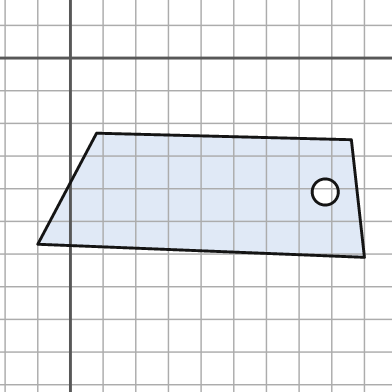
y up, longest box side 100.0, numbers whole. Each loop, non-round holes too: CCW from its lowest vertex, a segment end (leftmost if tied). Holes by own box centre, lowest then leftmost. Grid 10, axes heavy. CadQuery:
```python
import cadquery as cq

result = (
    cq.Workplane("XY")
    .moveTo(90.0, -61.0)
    .lineTo(86.0, -25.0)
    .lineTo(8.0, -23.0)
    .lineTo(-10.0, -57.0)
    .close()
    .moveTo(78.0, -41.0)
    .circle(4.0)
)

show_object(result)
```